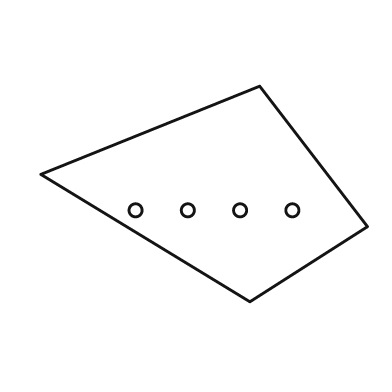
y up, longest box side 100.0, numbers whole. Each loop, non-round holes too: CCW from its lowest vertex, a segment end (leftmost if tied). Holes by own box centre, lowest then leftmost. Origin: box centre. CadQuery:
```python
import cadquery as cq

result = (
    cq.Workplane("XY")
    .moveTo(14.0, -33.0)
    .lineTo(50.0, -10.0)
    .lineTo(17.0, 33.0)
    .lineTo(-50.0, 6.0)
    .close()
    .moveTo(-21.0, -5.0)
    .circle(2.0)
    .moveTo(-5.0, -5.0)
    .circle(2.0)
    .moveTo(11.0, -5.0)
    .circle(2.0)
    .moveTo(27.0, -5.0)
    .circle(2.0)
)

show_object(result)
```